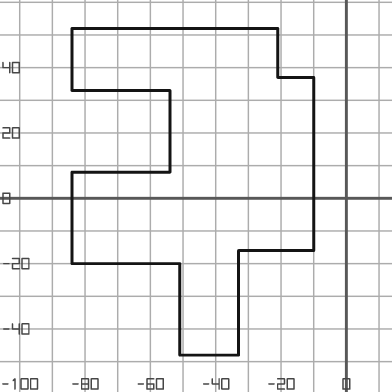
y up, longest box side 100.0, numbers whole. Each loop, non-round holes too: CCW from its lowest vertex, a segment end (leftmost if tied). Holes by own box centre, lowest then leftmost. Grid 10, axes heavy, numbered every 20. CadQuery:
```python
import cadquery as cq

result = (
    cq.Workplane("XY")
    .moveTo(-51.0, -48.0)
    .lineTo(-33.0, -48.0)
    .lineTo(-33.0, -16.0)
    .lineTo(-10.0, -16.0)
    .lineTo(-10.0, 37.0)
    .lineTo(-21.0, 37.0)
    .lineTo(-21.0, 52.0)
    .lineTo(-84.0, 52.0)
    .lineTo(-84.0, 33.0)
    .lineTo(-54.0, 33.0)
    .lineTo(-54.0, 8.0)
    .lineTo(-84.0, 8.0)
    .lineTo(-84.0, -20.0)
    .lineTo(-51.0, -20.0)
    .close()
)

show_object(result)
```